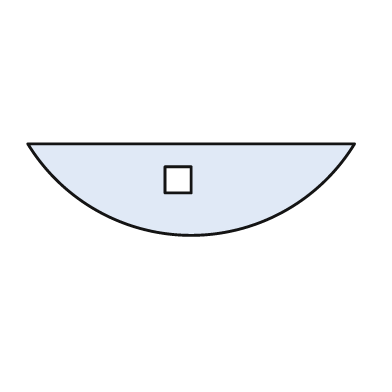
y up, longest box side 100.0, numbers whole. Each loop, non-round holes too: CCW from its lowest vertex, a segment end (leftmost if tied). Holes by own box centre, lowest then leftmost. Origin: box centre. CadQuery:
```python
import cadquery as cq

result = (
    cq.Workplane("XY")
    .moveTo(-50.0, 14.0)
    .threePointArc((0.0, -14.0), (50.0, 14.0))
    .close()
    .moveTo(-8.0, -1.0)
    .lineTo(0.0, -1.0)
    .lineTo(0.0, 7.0)
    .lineTo(-8.0, 7.0)
    .close()
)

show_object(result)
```